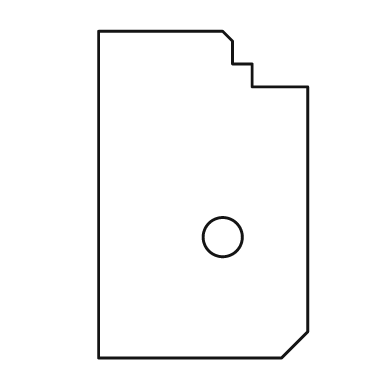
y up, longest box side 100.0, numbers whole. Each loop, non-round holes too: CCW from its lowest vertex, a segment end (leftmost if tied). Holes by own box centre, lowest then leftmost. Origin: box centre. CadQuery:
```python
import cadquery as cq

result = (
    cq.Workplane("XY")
    .moveTo(-32.0, -50.0)
    .lineTo(24.0, -50.0)
    .lineTo(32.0, -42.0)
    .lineTo(32.0, 33.0)
    .lineTo(15.0, 33.0)
    .lineTo(15.0, 40.0)
    .lineTo(9.0, 40.0)
    .lineTo(9.0, 47.0)
    .lineTo(6.0, 50.0)
    .lineTo(-32.0, 50.0)
    .close()
    .moveTo(6.0, -13.0)
    .circle(6.0)
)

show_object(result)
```